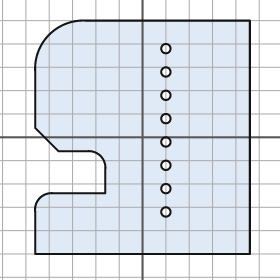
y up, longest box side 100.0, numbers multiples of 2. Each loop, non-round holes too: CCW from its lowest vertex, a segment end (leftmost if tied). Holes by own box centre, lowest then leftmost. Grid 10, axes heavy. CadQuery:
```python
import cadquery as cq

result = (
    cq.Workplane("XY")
    .moveTo(-46.0, -50.0)
    .lineTo(46.0, -50.0)
    .lineTo(46.0, 50.0)
    .lineTo(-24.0, 50.0)
    .threePointArc((-40.0, 44.0), (-46.0, 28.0))
    .lineTo(-46.0, 4.0)
    .lineTo(-36.0, -6.0)
    .lineTo(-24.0, -6.0)
    .threePointArc((-18.0, -8.0), (-16.0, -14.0))
    .lineTo(-16.0, -24.0)
    .lineTo(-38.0, -24.0)
    .threePointArc((-44.0, -26.0), (-46.0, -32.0))
    .close()
    .moveTo(10.0, -32.0)
    .circle(2.0)
    .moveTo(10.0, -22.0)
    .circle(2.0)
    .moveTo(10.0, -12.0)
    .circle(2.0)
    .moveTo(10.0, -2.0)
    .circle(2.0)
    .moveTo(10.0, 8.0)
    .circle(2.0)
    .moveTo(10.0, 18.0)
    .circle(2.0)
    .moveTo(10.0, 28.0)
    .circle(2.0)
    .moveTo(10.0, 38.0)
    .circle(2.0)
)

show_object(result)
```